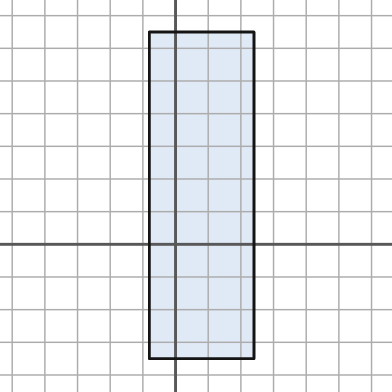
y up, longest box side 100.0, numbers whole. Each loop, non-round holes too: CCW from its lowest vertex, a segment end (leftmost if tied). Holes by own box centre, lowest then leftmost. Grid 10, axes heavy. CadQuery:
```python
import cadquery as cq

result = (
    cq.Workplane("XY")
    .moveTo(-8.0, -35.0)
    .lineTo(24.0, -35.0)
    .lineTo(24.0, 65.0)
    .lineTo(-8.0, 65.0)
    .close()
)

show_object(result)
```